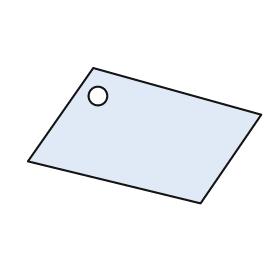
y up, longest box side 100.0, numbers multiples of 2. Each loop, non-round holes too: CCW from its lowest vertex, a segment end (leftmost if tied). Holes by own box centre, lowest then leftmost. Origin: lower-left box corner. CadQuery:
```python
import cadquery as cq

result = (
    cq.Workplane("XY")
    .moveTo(74.0, 0.0)
    .lineTo(100.0, 38.0)
    .lineTo(28.0, 58.0)
    .lineTo(0.0, 18.0)
    .close()
    .moveTo(30.0, 46.0)
    .circle(4.0)
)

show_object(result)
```